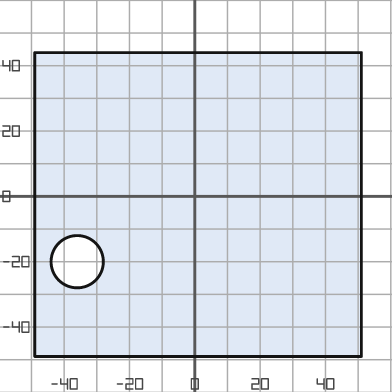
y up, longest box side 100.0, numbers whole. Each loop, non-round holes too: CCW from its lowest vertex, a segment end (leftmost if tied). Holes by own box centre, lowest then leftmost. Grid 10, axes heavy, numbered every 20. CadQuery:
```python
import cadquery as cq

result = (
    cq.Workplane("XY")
    .moveTo(-49.0, -49.0)
    .lineTo(51.0, -49.0)
    .lineTo(51.0, 44.0)
    .lineTo(-49.0, 44.0)
    .close()
    .moveTo(-36.0, -20.0)
    .circle(8.0)
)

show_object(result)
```